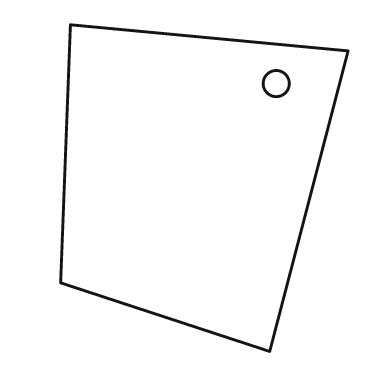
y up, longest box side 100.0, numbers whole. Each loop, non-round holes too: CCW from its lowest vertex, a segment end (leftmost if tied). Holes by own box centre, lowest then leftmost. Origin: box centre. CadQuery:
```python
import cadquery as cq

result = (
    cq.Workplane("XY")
    .moveTo(20.0, -50.0)
    .lineTo(44.0, 42.0)
    .lineTo(-41.0, 50.0)
    .lineTo(-44.0, -29.0)
    .close()
    .moveTo(22.0, 32.0)
    .circle(4.0)
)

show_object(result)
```